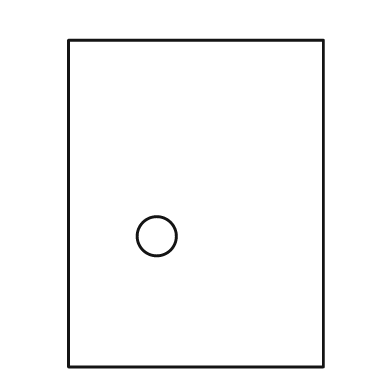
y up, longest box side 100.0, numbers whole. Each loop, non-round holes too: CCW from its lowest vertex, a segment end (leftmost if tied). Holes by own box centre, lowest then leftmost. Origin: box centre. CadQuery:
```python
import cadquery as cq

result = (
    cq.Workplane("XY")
    .moveTo(-39.0, -50.0)
    .lineTo(39.0, -50.0)
    .lineTo(39.0, 50.0)
    .lineTo(-39.0, 50.0)
    .close()
    .moveTo(-12.0, -10.0)
    .circle(6.0)
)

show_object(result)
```